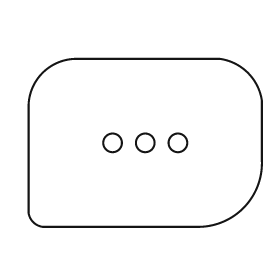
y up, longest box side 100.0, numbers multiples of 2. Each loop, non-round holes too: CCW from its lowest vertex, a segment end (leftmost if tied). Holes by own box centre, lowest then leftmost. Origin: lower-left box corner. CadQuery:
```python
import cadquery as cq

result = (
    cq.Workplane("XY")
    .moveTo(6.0, 0.0)
    .lineTo(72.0, 0.0)
    .threePointArc((92.0, 8.0), (100.0, 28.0))
    .lineTo(100.0, 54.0)
    .threePointArc((94.0, 66.0), (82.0, 72.0))
    .lineTo(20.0, 72.0)
    .threePointArc((6.0, 66.0), (0.0, 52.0))
    .lineTo(0.0, 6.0)
    .threePointArc((2.0, 2.0), (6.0, 0.0))
    .close()
    .moveTo(36.0, 36.0)
    .circle(4.0)
    .moveTo(50.0, 36.0)
    .circle(4.0)
    .moveTo(64.0, 36.0)
    .circle(4.0)
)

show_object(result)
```